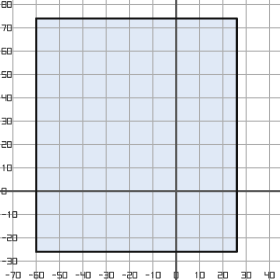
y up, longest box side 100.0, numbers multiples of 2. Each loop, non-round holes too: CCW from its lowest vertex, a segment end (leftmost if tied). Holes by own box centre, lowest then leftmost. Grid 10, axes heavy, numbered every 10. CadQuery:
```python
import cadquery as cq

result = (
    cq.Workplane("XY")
    .moveTo(-60.0, -26.0)
    .lineTo(26.0, -26.0)
    .lineTo(26.0, 74.0)
    .lineTo(-60.0, 74.0)
    .close()
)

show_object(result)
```